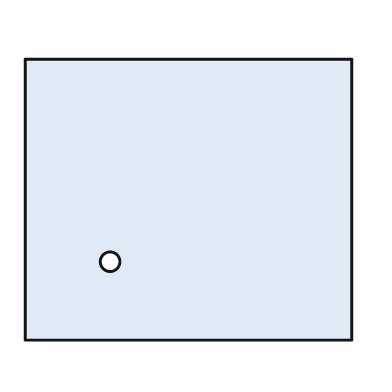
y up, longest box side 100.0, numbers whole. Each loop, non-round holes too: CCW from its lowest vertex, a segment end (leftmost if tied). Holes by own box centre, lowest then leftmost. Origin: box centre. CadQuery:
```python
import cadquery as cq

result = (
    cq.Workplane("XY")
    .moveTo(-50.0, -43.0)
    .lineTo(50.0, -43.0)
    .lineTo(50.0, 43.0)
    .lineTo(-50.0, 43.0)
    .close()
    .moveTo(-24.0, -19.0)
    .circle(3.0)
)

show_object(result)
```